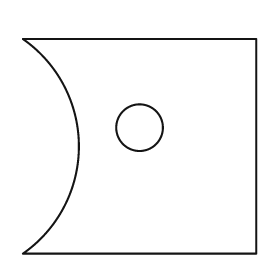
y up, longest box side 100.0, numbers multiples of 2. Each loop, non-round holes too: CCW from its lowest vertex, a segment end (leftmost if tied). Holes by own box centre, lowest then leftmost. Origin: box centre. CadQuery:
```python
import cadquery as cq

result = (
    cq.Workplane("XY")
    .moveTo(-50.0, -46.0)
    .lineTo(50.0, -46.0)
    .lineTo(50.0, 46.0)
    .lineTo(-50.0, 46.0)
    .threePointArc((-26.0, 0.0), (-50.0, -46.0))
    .close()
    .moveTo(0.0, 8.0)
    .circle(10.0)
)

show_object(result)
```